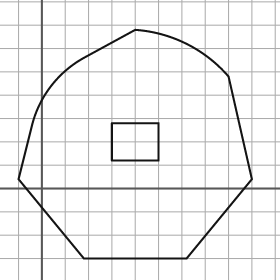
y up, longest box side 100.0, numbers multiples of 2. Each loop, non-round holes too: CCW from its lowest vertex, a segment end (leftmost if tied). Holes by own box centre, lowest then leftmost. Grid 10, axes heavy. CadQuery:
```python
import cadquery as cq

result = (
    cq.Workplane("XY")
    .moveTo(18.0, -30.0)
    .lineTo(62.0, -30.0)
    .lineTo(90.0, 4.0)
    .lineTo(80.0, 48.0)
    .threePointArc((62.0, 62.0), (40.0, 68.0))
    .lineTo(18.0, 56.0)
    .threePointArc((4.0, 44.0), (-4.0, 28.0))
    .lineTo(-10.0, 4.0)
    .close()
    .moveTo(30.0, 12.0)
    .lineTo(50.0, 12.0)
    .lineTo(50.0, 28.0)
    .lineTo(30.0, 28.0)
    .close()
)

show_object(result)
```